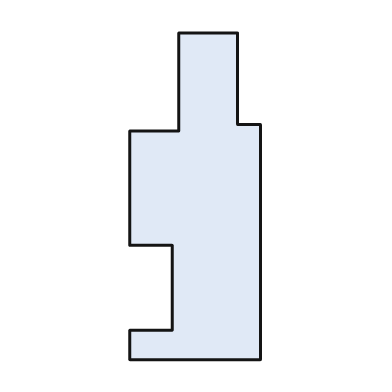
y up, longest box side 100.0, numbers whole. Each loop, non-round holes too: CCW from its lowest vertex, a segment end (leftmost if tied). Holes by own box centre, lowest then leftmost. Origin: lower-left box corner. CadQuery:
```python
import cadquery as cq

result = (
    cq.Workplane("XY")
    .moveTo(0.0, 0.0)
    .lineTo(40.0, 0.0)
    .lineTo(40.0, 72.0)
    .lineTo(33.0, 72.0)
    .lineTo(33.0, 100.0)
    .lineTo(15.0, 100.0)
    .lineTo(15.0, 70.0)
    .lineTo(0.0, 70.0)
    .lineTo(0.0, 35.0)
    .lineTo(13.0, 35.0)
    .lineTo(13.0, 9.0)
    .lineTo(0.0, 9.0)
    .close()
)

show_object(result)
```